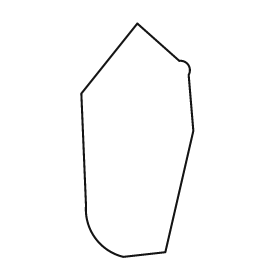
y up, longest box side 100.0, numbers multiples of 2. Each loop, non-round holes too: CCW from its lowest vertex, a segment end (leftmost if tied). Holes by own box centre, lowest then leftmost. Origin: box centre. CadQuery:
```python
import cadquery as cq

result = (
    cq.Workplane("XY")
    .moveTo(-6.0, -50.0)
    .lineTo(12.0, -48.0)
    .lineTo(24.0, 4.0)
    .lineTo(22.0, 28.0)
    .threePointArc((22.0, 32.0), (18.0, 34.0))
    .lineTo(0.0, 50.0)
    .lineTo(-24.0, 20.0)
    .lineTo(-22.0, -28.0)
    .threePointArc((-18.0, -42.0), (-6.0, -50.0))
    .close()
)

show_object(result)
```